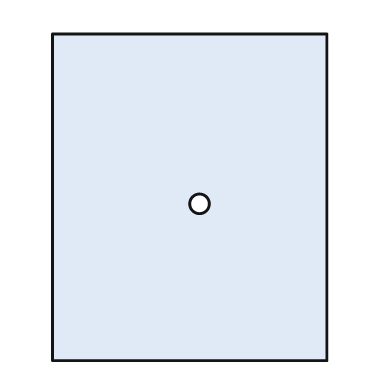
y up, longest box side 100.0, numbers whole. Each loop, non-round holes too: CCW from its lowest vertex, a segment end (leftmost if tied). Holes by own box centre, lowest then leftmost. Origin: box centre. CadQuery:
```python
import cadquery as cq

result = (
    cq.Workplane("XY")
    .moveTo(-42.0, -50.0)
    .lineTo(42.0, -50.0)
    .lineTo(42.0, 50.0)
    .lineTo(-42.0, 50.0)
    .close()
    .moveTo(3.0, -2.0)
    .circle(3.0)
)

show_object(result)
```